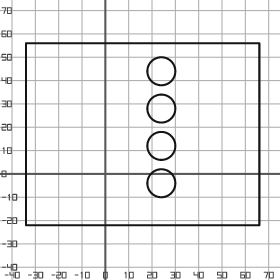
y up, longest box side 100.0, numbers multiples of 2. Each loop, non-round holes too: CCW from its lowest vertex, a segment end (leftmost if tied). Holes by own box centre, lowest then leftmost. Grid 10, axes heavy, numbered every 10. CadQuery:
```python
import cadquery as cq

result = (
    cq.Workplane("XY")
    .moveTo(-34.0, -22.0)
    .lineTo(66.0, -22.0)
    .lineTo(66.0, 56.0)
    .lineTo(-34.0, 56.0)
    .close()
    .moveTo(24.0, -4.0)
    .circle(6.0)
    .moveTo(24.0, 12.0)
    .circle(6.0)
    .moveTo(24.0, 28.0)
    .circle(6.0)
    .moveTo(24.0, 44.0)
    .circle(6.0)
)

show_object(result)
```